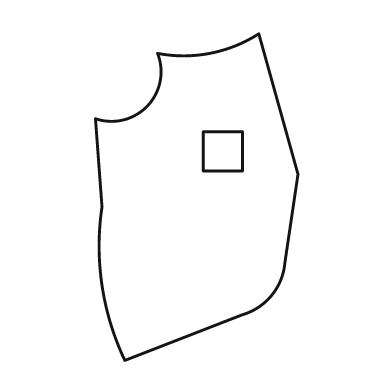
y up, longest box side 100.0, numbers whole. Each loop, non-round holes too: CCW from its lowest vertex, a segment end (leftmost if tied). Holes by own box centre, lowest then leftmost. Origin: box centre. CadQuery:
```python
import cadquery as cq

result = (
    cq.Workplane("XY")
    .moveTo(-22.0, -50.0)
    .lineTo(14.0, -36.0)
    .threePointArc((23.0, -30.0), (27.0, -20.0))
    .lineTo(31.0, 7.0)
    .lineTo(19.0, 50.0)
    .threePointArc((4.0, 44.0), (-12.0, 44.0))
    .threePointArc((-15.0, 28.0), (-31.0, 24.0))
    .lineTo(-29.0, -3.0)
    .threePointArc((-29.0, -27.0), (-22.0, -50.0))
    .close()
    .moveTo(2.0, 8.0)
    .lineTo(14.0, 8.0)
    .lineTo(14.0, 20.0)
    .lineTo(2.0, 20.0)
    .close()
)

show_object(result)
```